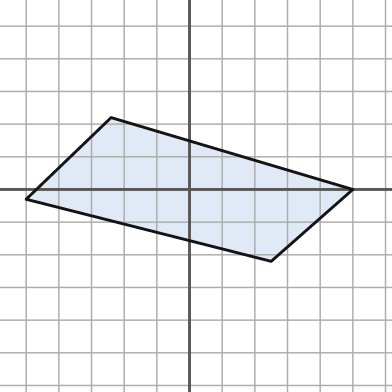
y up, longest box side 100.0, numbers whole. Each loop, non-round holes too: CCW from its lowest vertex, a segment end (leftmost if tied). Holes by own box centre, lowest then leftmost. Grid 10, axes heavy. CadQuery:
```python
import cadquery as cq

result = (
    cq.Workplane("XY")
    .moveTo(25.0, -22.0)
    .lineTo(50.0, 0.0)
    .lineTo(-24.0, 22.0)
    .lineTo(-50.0, -3.0)
    .close()
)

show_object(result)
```